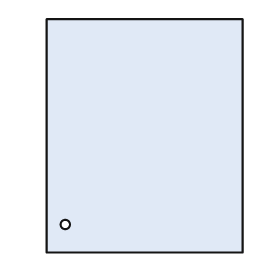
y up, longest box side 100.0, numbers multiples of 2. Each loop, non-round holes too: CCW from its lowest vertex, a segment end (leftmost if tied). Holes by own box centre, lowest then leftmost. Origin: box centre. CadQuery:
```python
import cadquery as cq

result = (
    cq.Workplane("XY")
    .moveTo(-42.0, -50.0)
    .lineTo(42.0, -50.0)
    .lineTo(42.0, 50.0)
    .lineTo(-42.0, 50.0)
    .close()
    .moveTo(-34.0, -38.0)
    .circle(2.0)
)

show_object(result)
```